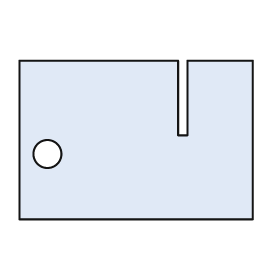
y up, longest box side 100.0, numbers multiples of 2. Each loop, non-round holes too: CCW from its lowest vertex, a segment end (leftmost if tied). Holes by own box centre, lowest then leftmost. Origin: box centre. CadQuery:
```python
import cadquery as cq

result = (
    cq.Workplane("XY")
    .moveTo(-50.0, -34.0)
    .lineTo(50.0, -34.0)
    .lineTo(50.0, 34.0)
    .lineTo(22.0, 34.0)
    .lineTo(22.0, 2.0)
    .lineTo(18.0, 2.0)
    .lineTo(18.0, 34.0)
    .lineTo(-50.0, 34.0)
    .close()
    .moveTo(-38.0, -6.0)
    .circle(6.0)
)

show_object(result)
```